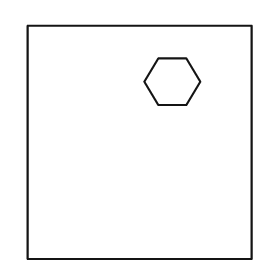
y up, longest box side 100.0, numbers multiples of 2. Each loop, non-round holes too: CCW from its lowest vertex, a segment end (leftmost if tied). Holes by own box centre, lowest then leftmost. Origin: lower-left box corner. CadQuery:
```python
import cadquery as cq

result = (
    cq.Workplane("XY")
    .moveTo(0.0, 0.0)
    .lineTo(96.0, 0.0)
    .lineTo(96.0, 100.0)
    .lineTo(0.0, 100.0)
    .close()
    .moveTo(56.0, 66.0)
    .lineTo(68.0, 66.0)
    .lineTo(74.0, 76.0)
    .lineTo(68.0, 86.0)
    .lineTo(56.0, 86.0)
    .lineTo(50.0, 76.0)
    .close()
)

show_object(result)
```